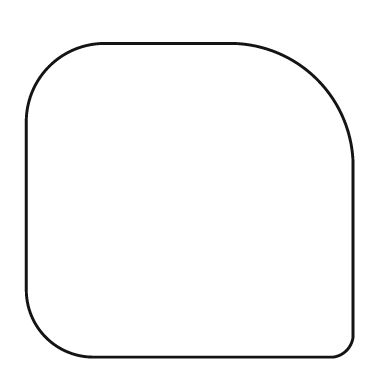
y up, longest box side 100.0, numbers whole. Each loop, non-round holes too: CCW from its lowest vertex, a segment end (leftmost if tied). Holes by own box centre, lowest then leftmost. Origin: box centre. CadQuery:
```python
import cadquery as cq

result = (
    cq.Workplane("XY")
    .moveTo(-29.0, -48.0)
    .lineTo(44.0, -48.0)
    .threePointArc((48.0, -46.0), (50.0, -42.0))
    .lineTo(50.0, 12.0)
    .threePointArc((39.0, 37.0), (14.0, 48.0))
    .lineTo(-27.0, 48.0)
    .threePointArc((-43.0, 41.0), (-50.0, 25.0))
    .lineTo(-50.0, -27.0)
    .threePointArc((-44.0, -42.0), (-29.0, -48.0))
    .close()
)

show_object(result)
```